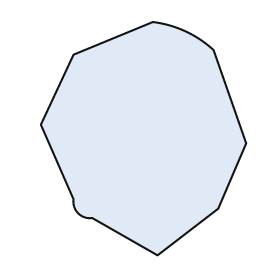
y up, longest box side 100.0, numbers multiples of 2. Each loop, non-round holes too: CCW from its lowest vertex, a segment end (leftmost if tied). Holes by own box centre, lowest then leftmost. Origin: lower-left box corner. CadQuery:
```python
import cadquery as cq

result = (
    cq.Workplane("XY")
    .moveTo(50.0, 0.0)
    .lineTo(76.0, 20.0)
    .lineTo(88.0, 48.0)
    .lineTo(74.0, 88.0)
    .threePointArc((62.0, 96.0), (48.0, 100.0))
    .lineTo(14.0, 86.0)
    .lineTo(0.0, 56.0)
    .lineTo(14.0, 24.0)
    .threePointArc((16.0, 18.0), (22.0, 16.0))
    .close()
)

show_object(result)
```